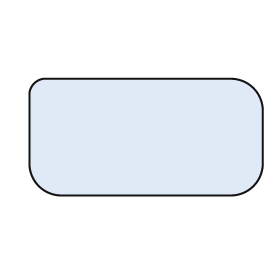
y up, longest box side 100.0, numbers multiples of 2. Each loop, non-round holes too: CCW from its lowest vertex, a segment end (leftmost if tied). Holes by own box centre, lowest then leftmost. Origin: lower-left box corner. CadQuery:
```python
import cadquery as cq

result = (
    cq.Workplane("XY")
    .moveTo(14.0, 0.0)
    .lineTo(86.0, 0.0)
    .threePointArc((96.0, 4.0), (100.0, 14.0))
    .lineTo(100.0, 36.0)
    .threePointArc((96.0, 46.0), (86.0, 50.0))
    .lineTo(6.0, 50.0)
    .threePointArc((2.0, 48.0), (0.0, 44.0))
    .lineTo(0.0, 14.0)
    .threePointArc((4.0, 4.0), (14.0, 0.0))
    .close()
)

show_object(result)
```